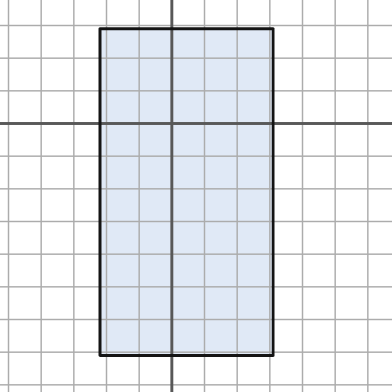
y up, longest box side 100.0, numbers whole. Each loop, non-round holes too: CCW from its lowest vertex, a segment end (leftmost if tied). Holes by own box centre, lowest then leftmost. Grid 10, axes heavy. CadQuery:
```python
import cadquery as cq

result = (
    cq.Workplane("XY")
    .moveTo(-22.0, -71.0)
    .lineTo(31.0, -71.0)
    .lineTo(31.0, 29.0)
    .lineTo(-22.0, 29.0)
    .close()
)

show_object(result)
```